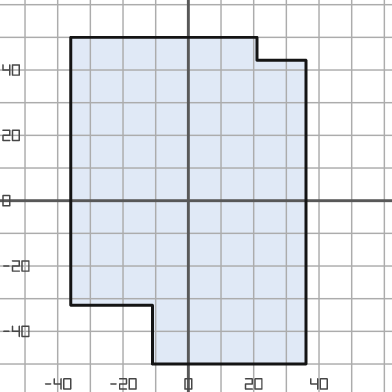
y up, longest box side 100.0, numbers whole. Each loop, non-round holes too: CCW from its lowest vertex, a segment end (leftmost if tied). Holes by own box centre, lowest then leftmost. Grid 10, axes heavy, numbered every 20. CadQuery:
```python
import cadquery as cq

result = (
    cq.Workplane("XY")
    .moveTo(-11.0, -50.0)
    .lineTo(36.0, -50.0)
    .lineTo(36.0, 43.0)
    .lineTo(21.0, 43.0)
    .lineTo(21.0, 50.0)
    .lineTo(-36.0, 50.0)
    .lineTo(-36.0, -32.0)
    .lineTo(-11.0, -32.0)
    .close()
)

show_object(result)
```